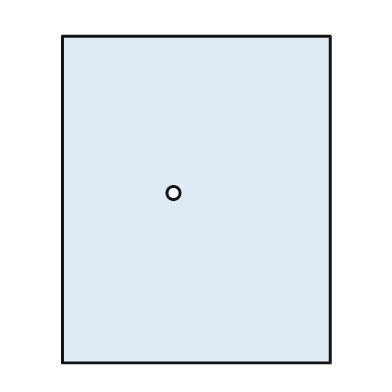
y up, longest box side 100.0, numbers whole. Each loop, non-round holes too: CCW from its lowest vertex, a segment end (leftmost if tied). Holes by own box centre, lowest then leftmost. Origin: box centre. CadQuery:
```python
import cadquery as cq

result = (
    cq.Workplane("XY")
    .moveTo(-41.0, -50.0)
    .lineTo(41.0, -50.0)
    .lineTo(41.0, 50.0)
    .lineTo(-41.0, 50.0)
    .close()
    .moveTo(-7.0, 2.0)
    .circle(2.0)
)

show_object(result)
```